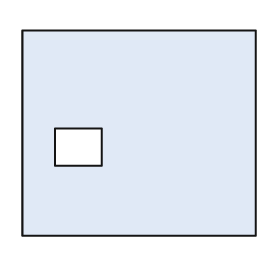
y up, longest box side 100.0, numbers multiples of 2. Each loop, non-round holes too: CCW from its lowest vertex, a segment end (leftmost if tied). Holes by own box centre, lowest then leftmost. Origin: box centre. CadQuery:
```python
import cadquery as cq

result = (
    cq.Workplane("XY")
    .moveTo(-50.0, -44.0)
    .lineTo(50.0, -44.0)
    .lineTo(50.0, 44.0)
    .lineTo(-50.0, 44.0)
    .close()
    .moveTo(-36.0, -14.0)
    .lineTo(-16.0, -14.0)
    .lineTo(-16.0, 2.0)
    .lineTo(-36.0, 2.0)
    .close()
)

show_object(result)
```